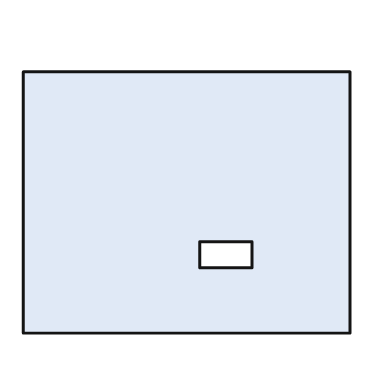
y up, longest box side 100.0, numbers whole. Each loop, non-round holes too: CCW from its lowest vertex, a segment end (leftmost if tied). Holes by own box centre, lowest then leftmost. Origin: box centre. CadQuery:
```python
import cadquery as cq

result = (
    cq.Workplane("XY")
    .moveTo(-50.0, -40.0)
    .lineTo(50.0, -40.0)
    .lineTo(50.0, 40.0)
    .lineTo(-50.0, 40.0)
    .close()
    .moveTo(4.0, -20.0)
    .lineTo(20.0, -20.0)
    .lineTo(20.0, -12.0)
    .lineTo(4.0, -12.0)
    .close()
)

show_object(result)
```